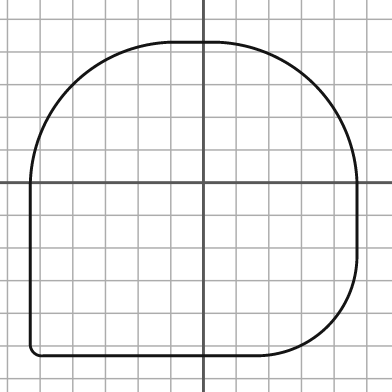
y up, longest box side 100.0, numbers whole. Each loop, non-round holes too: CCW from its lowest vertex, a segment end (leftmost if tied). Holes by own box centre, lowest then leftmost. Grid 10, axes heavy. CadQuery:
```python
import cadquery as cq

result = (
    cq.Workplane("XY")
    .moveTo(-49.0, -53.0)
    .lineTo(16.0, -53.0)
    .threePointArc((38.0, -44.0), (47.0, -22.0))
    .lineTo(47.0, 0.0)
    .threePointArc((34.0, 30.0), (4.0, 43.0))
    .lineTo(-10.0, 43.0)
    .threePointArc((-40.0, 30.0), (-53.0, 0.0))
    .lineTo(-53.0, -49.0)
    .threePointArc((-52.0, -52.0), (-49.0, -53.0))
    .close()
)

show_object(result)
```